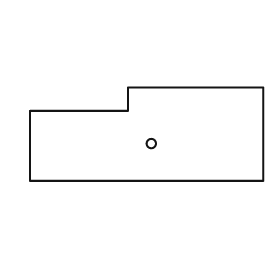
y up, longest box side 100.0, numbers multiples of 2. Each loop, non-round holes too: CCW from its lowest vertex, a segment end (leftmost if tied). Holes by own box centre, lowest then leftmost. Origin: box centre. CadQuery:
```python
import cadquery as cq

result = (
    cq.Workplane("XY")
    .moveTo(-50.0, -20.0)
    .lineTo(50.0, -20.0)
    .lineTo(50.0, 20.0)
    .lineTo(-8.0, 20.0)
    .lineTo(-8.0, 10.0)
    .lineTo(-50.0, 10.0)
    .close()
    .moveTo(2.0, -4.0)
    .circle(2.0)
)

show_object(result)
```